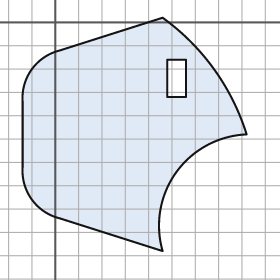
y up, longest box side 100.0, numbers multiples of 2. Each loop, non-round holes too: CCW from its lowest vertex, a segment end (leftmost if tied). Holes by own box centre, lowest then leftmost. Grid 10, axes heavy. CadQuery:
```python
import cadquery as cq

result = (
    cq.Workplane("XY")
    .moveTo(46.0, -98.0)
    .threePointArc((52.0, -64.0), (82.0, -48.0))
    .threePointArc((68.0, -20.0), (46.0, 2.0))
    .lineTo(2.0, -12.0)
    .threePointArc((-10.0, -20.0), (-14.0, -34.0))
    .lineTo(-14.0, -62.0)
    .threePointArc((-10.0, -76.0), (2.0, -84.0))
    .close()
    .moveTo(48.0, -32.0)
    .lineTo(56.0, -32.0)
    .lineTo(56.0, -16.0)
    .lineTo(48.0, -16.0)
    .close()
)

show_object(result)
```